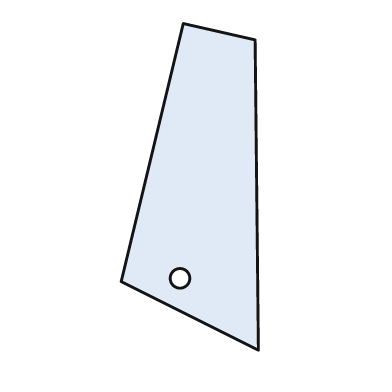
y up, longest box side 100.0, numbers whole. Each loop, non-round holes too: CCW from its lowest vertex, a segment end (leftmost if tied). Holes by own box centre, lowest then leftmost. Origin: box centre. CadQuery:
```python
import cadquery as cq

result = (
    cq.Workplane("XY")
    .moveTo(21.0, -50.0)
    .lineTo(20.0, 45.0)
    .lineTo(-2.0, 50.0)
    .lineTo(-21.0, -29.0)
    .close()
    .moveTo(-3.0, -28.0)
    .circle(3.0)
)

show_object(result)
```